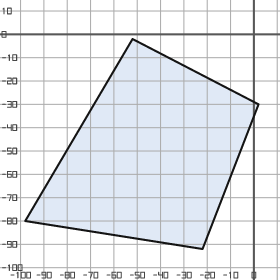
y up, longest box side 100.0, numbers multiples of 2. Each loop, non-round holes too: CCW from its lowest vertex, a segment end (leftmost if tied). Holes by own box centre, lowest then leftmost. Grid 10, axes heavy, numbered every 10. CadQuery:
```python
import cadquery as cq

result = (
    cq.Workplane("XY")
    .moveTo(-22.0, -92.0)
    .lineTo(2.0, -30.0)
    .lineTo(-52.0, -2.0)
    .lineTo(-98.0, -80.0)
    .close()
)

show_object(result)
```